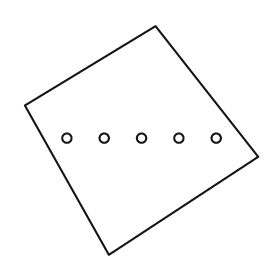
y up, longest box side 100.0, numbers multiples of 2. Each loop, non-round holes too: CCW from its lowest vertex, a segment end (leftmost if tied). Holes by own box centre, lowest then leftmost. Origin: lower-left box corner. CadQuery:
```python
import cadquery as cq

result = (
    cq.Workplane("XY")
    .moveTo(36.0, 0.0)
    .lineTo(100.0, 42.0)
    .lineTo(56.0, 98.0)
    .lineTo(0.0, 64.0)
    .close()
    .moveTo(18.0, 50.0)
    .circle(2.0)
    .moveTo(34.0, 50.0)
    .circle(2.0)
    .moveTo(50.0, 50.0)
    .circle(2.0)
    .moveTo(66.0, 50.0)
    .circle(2.0)
    .moveTo(82.0, 50.0)
    .circle(2.0)
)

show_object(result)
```